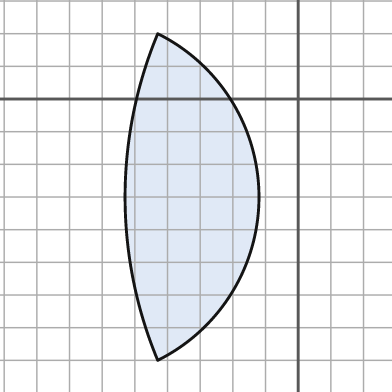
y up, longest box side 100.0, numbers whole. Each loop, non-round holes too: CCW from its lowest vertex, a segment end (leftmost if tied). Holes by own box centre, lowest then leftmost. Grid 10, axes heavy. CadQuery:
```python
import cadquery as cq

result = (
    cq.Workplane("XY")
    .moveTo(-43.0, -80.0)
    .threePointArc((-12.0, -30.0), (-43.0, 20.0))
    .threePointArc((-53.0, -30.0), (-43.0, -80.0))
    .close()
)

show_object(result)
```